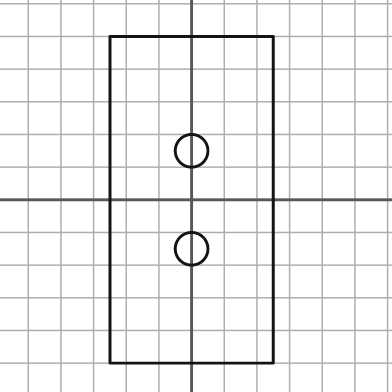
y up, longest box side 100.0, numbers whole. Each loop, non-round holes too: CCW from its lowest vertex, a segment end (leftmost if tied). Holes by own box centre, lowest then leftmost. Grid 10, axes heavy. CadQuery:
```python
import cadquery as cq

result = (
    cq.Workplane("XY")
    .moveTo(-25.0, -50.0)
    .lineTo(25.0, -50.0)
    .lineTo(25.0, 50.0)
    .lineTo(-25.0, 50.0)
    .close()
    .moveTo(0.0, -15.0)
    .circle(5.0)
    .moveTo(0.0, 15.0)
    .circle(5.0)
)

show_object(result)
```